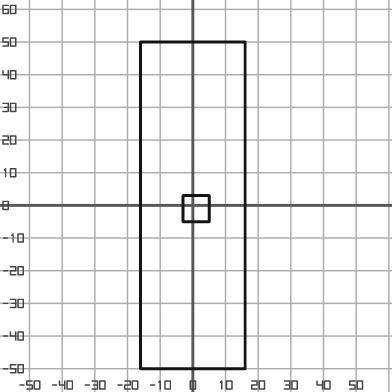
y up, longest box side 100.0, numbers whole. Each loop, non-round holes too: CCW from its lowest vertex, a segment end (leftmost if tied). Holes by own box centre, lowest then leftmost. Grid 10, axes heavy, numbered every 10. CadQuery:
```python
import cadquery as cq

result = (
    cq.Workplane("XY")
    .moveTo(-16.0, -50.0)
    .lineTo(16.0, -50.0)
    .lineTo(16.0, 50.0)
    .lineTo(-16.0, 50.0)
    .close()
    .moveTo(-3.0, -5.0)
    .lineTo(5.0, -5.0)
    .lineTo(5.0, 3.0)
    .lineTo(-3.0, 3.0)
    .close()
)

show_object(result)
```